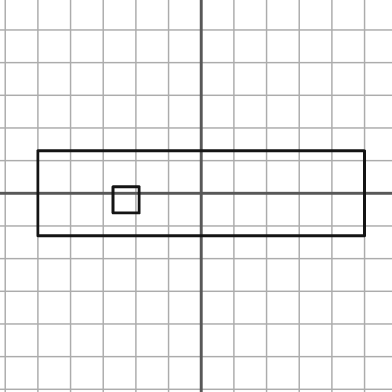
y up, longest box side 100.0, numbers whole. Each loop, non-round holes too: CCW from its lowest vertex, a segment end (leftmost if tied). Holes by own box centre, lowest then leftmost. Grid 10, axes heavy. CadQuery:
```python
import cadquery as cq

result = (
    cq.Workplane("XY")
    .moveTo(-50.0, -13.0)
    .lineTo(50.0, -13.0)
    .lineTo(50.0, 13.0)
    .lineTo(-50.0, 13.0)
    .close()
    .moveTo(-27.0, -6.0)
    .lineTo(-19.0, -6.0)
    .lineTo(-19.0, 2.0)
    .lineTo(-27.0, 2.0)
    .close()
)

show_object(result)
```